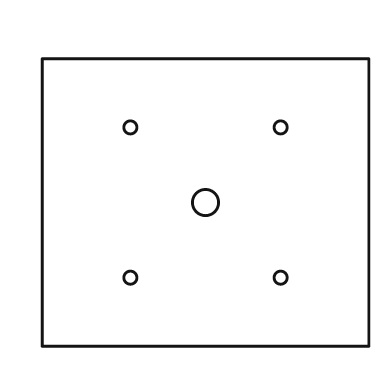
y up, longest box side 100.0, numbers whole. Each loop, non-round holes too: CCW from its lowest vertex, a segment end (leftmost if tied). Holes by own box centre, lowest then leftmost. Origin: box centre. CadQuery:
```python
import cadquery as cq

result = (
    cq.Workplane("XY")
    .moveTo(-50.0, -44.0)
    .lineTo(50.0, -44.0)
    .lineTo(50.0, 44.0)
    .lineTo(-50.0, 44.0)
    .close()
    .moveTo(-23.0, -23.0)
    .circle(2.0)
    .moveTo(23.0, -23.0)
    .circle(2.0)
    .moveTo(0.0, 0.0)
    .circle(4.0)
    .moveTo(-23.0, 23.0)
    .circle(2.0)
    .moveTo(23.0, 23.0)
    .circle(2.0)
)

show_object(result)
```